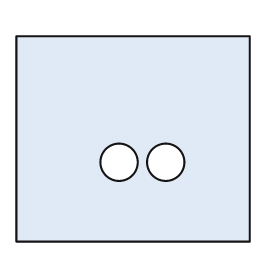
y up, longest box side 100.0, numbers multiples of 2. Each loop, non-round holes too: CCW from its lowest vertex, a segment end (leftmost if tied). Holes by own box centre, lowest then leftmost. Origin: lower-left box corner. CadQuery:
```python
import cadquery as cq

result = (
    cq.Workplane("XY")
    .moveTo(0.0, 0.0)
    .lineTo(100.0, 0.0)
    .lineTo(100.0, 88.0)
    .lineTo(0.0, 88.0)
    .close()
    .moveTo(44.0, 34.0)
    .circle(8.0)
    .moveTo(64.0, 34.0)
    .circle(8.0)
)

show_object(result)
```